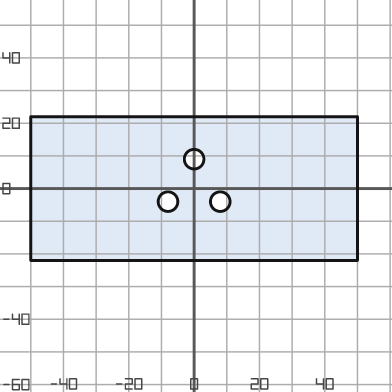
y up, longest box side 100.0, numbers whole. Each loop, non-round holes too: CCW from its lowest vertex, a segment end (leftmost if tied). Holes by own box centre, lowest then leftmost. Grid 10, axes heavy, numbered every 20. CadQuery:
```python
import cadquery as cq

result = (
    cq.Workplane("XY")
    .moveTo(-50.0, -22.0)
    .lineTo(50.0, -22.0)
    .lineTo(50.0, 22.0)
    .lineTo(-50.0, 22.0)
    .close()
    .moveTo(-8.0, -4.0)
    .circle(3.0)
    .moveTo(8.0, -4.0)
    .circle(3.0)
    .moveTo(0.0, 9.0)
    .circle(3.0)
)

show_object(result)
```